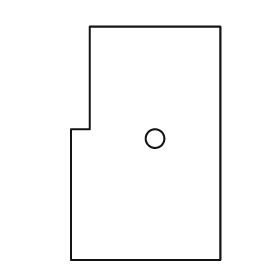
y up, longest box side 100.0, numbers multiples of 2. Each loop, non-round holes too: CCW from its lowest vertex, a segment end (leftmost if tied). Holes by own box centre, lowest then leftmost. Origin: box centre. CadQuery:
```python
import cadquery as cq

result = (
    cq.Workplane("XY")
    .moveTo(-32.0, -50.0)
    .lineTo(32.0, -50.0)
    .lineTo(32.0, 50.0)
    .lineTo(-24.0, 50.0)
    .lineTo(-24.0, 6.0)
    .lineTo(-32.0, 6.0)
    .close()
    .moveTo(4.0, 2.0)
    .circle(4.0)
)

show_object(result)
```